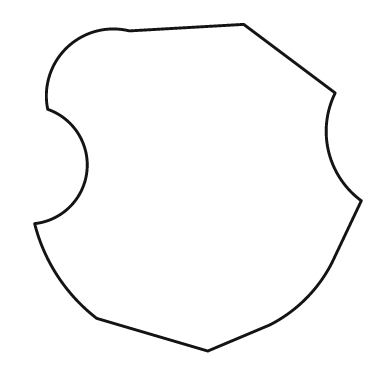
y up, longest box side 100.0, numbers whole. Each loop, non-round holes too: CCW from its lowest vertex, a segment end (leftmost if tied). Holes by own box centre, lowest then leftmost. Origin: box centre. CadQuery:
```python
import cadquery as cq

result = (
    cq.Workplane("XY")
    .moveTo(3.0, -50.0)
    .lineTo(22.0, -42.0)
    .threePointArc((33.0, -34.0), (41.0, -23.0))
    .lineTo(50.0, -4.0)
    .threePointArc((40.0, 11.0), (42.0, 29.0))
    .lineTo(14.0, 50.0)
    .lineTo(-21.0, 48.0)
    .threePointArc((-40.0, 43.0), (-46.0, 24.0))
    .threePointArc((-34.0, 5.0), (-50.0, -11.0))
    .threePointArc((-43.0, -27.0), (-31.0, -40.0))
    .close()
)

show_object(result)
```